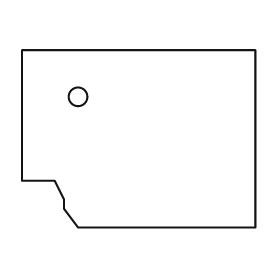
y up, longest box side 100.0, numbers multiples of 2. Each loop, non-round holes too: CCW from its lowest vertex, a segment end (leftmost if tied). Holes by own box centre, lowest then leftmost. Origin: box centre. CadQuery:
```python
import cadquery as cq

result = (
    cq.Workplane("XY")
    .moveTo(-26.0, -38.0)
    .lineTo(50.0, -38.0)
    .lineTo(50.0, 38.0)
    .lineTo(-50.0, 38.0)
    .lineTo(-50.0, -18.0)
    .lineTo(-36.0, -18.0)
    .lineTo(-32.0, -26.0)
    .lineTo(-32.0, -30.0)
    .close()
    .moveTo(-26.0, 18.0)
    .circle(4.0)
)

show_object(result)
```